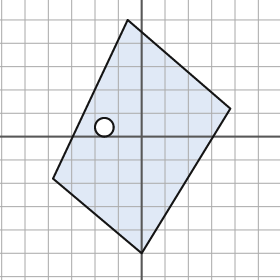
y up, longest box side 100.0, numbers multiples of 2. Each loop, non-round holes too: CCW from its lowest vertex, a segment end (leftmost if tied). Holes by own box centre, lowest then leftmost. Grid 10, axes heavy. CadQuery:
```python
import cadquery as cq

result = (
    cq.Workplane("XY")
    .moveTo(0.0, -50.0)
    .lineTo(38.0, 12.0)
    .lineTo(-6.0, 50.0)
    .lineTo(-38.0, -18.0)
    .close()
    .moveTo(-16.0, 4.0)
    .circle(4.0)
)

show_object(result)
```